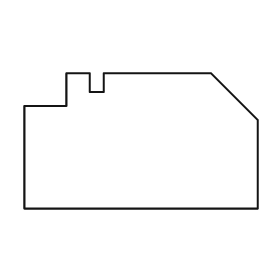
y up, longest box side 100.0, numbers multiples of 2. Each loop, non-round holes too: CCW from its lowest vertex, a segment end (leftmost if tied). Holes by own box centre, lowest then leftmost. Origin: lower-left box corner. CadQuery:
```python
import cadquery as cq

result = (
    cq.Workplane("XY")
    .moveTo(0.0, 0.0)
    .lineTo(100.0, 0.0)
    .lineTo(100.0, 38.0)
    .lineTo(80.0, 58.0)
    .lineTo(34.0, 58.0)
    .lineTo(34.0, 50.0)
    .lineTo(28.0, 50.0)
    .lineTo(28.0, 58.0)
    .lineTo(18.0, 58.0)
    .lineTo(18.0, 44.0)
    .lineTo(0.0, 44.0)
    .close()
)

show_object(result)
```